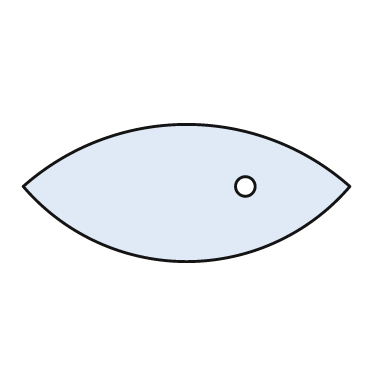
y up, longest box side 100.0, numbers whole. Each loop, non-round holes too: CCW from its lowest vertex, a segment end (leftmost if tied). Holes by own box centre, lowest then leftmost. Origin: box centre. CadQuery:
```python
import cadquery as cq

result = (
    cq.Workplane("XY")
    .moveTo(-50.0, 2.0)
    .threePointArc((0.0, -21.0), (50.0, 2.0))
    .threePointArc((0.0, 21.0), (-50.0, 2.0))
    .close()
    .moveTo(18.0, 2.0)
    .circle(3.0)
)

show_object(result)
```